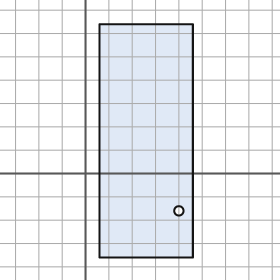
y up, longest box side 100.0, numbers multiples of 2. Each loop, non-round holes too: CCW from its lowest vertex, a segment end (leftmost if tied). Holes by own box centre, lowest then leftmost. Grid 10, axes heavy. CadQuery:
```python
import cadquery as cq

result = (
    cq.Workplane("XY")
    .moveTo(6.0, -36.0)
    .lineTo(46.0, -36.0)
    .lineTo(46.0, 64.0)
    .lineTo(6.0, 64.0)
    .close()
    .moveTo(40.0, -16.0)
    .circle(2.0)
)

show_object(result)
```